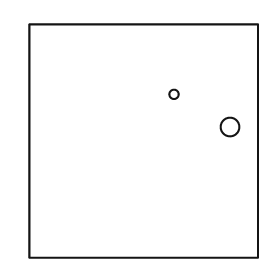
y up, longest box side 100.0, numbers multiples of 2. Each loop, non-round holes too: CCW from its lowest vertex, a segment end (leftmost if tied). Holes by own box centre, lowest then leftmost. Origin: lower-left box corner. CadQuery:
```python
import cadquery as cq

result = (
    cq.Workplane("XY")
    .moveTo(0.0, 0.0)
    .lineTo(98.0, 0.0)
    .lineTo(98.0, 100.0)
    .lineTo(0.0, 100.0)
    .close()
    .moveTo(86.0, 56.0)
    .circle(4.0)
    .moveTo(62.0, 70.0)
    .circle(2.0)
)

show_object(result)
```